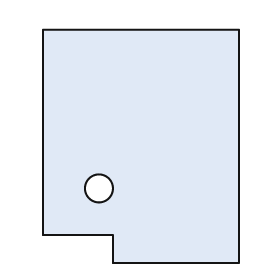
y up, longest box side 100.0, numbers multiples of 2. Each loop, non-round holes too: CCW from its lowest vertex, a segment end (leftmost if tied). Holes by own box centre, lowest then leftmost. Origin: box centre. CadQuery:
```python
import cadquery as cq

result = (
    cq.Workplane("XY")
    .moveTo(-12.0, -50.0)
    .lineTo(42.0, -50.0)
    .lineTo(42.0, 50.0)
    .lineTo(-42.0, 50.0)
    .lineTo(-42.0, -38.0)
    .lineTo(-12.0, -38.0)
    .close()
    .moveTo(-18.0, -18.0)
    .circle(6.0)
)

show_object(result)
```